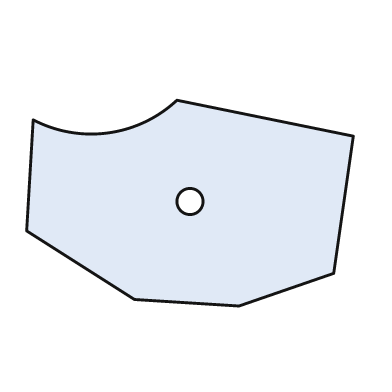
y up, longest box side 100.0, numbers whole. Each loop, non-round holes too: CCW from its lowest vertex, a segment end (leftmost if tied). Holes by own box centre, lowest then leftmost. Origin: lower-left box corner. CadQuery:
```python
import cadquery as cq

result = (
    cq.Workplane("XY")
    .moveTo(65.0, 0.0)
    .lineTo(94.0, 10.0)
    .lineTo(100.0, 52.0)
    .lineTo(46.0, 63.0)
    .threePointArc((25.0, 53.0), (2.0, 57.0))
    .lineTo(0.0, 23.0)
    .lineTo(33.0, 2.0)
    .close()
    .moveTo(50.0, 32.0)
    .circle(4.0)
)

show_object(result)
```